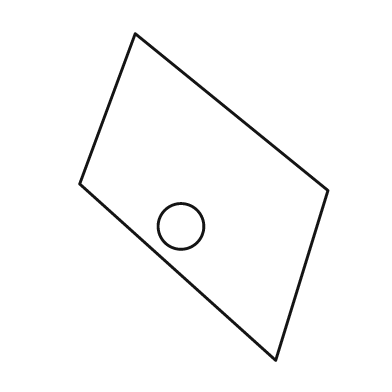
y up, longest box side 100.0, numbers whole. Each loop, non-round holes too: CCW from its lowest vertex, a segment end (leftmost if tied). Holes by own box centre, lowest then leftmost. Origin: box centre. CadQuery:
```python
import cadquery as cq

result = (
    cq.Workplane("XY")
    .moveTo(22.0, -50.0)
    .lineTo(38.0, 2.0)
    .lineTo(-21.0, 50.0)
    .lineTo(-38.0, 4.0)
    .close()
    .moveTo(-7.0, -9.0)
    .circle(7.0)
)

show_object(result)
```